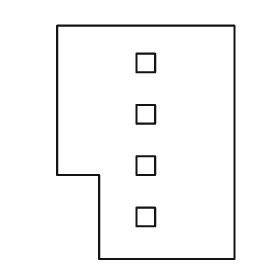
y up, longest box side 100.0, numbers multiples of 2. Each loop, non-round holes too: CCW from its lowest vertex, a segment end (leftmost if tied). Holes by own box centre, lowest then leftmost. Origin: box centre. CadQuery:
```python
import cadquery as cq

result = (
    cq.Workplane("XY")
    .moveTo(-20.0, -50.0)
    .lineTo(38.0, -50.0)
    .lineTo(38.0, 50.0)
    .lineTo(-38.0, 50.0)
    .lineTo(-38.0, -14.0)
    .lineTo(-20.0, -14.0)
    .close()
    .moveTo(-4.0, -36.0)
    .lineTo(4.0, -36.0)
    .lineTo(4.0, -28.0)
    .lineTo(-4.0, -28.0)
    .close()
    .moveTo(-4.0, -14.0)
    .lineTo(4.0, -14.0)
    .lineTo(4.0, -6.0)
    .lineTo(-4.0, -6.0)
    .close()
    .moveTo(-4.0, 8.0)
    .lineTo(4.0, 8.0)
    .lineTo(4.0, 16.0)
    .lineTo(-4.0, 16.0)
    .close()
    .moveTo(-4.0, 30.0)
    .lineTo(4.0, 30.0)
    .lineTo(4.0, 38.0)
    .lineTo(-4.0, 38.0)
    .close()
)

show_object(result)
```